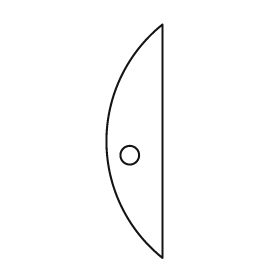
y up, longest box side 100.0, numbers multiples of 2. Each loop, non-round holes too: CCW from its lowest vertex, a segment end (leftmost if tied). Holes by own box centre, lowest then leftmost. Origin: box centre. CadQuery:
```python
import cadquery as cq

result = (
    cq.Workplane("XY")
    .moveTo(12.0, -50.0)
    .lineTo(12.0, 50.0)
    .threePointArc((-12.0, 0.0), (12.0, -50.0))
    .close()
    .moveTo(-2.0, -6.0)
    .circle(4.0)
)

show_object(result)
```